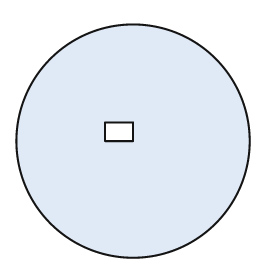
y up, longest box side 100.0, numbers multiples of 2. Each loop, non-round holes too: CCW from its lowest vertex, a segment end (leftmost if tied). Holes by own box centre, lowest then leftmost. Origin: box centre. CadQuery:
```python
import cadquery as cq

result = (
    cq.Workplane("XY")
    .moveTo(0.0, 0.0)
    .circle(50.0)
    .moveTo(-12.0, 0.0)
    .lineTo(0.0, 0.0)
    .lineTo(0.0, 8.0)
    .lineTo(-12.0, 8.0)
    .close()
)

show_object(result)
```